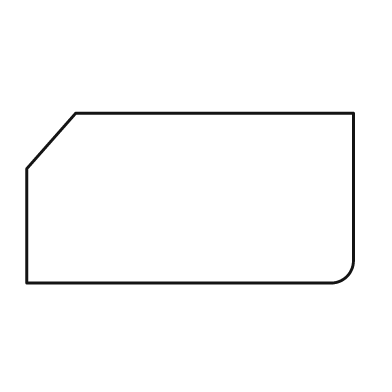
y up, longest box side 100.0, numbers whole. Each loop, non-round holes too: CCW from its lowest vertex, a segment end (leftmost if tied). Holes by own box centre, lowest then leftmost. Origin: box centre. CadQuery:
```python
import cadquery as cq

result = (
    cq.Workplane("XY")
    .moveTo(-50.0, -26.0)
    .lineTo(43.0, -26.0)
    .threePointArc((48.0, -24.0), (50.0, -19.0))
    .lineTo(50.0, 26.0)
    .lineTo(-35.0, 26.0)
    .lineTo(-50.0, 9.0)
    .close()
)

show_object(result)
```